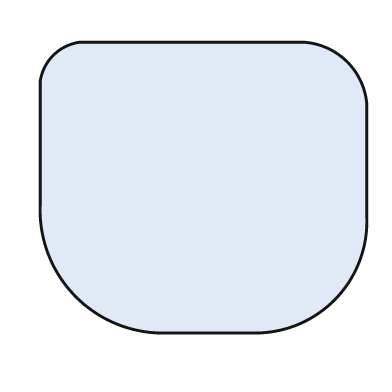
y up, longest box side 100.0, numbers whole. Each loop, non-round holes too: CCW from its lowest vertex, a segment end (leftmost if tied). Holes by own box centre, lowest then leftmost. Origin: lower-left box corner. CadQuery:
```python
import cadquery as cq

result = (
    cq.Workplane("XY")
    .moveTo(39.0, 0.0)
    .lineTo(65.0, 0.0)
    .threePointArc((90.0, 10.0), (100.0, 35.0))
    .lineTo(100.0, 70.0)
    .threePointArc((94.0, 83.0), (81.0, 89.0))
    .lineTo(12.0, 89.0)
    .threePointArc((4.0, 85.0), (0.0, 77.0))
    .lineTo(0.0, 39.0)
    .threePointArc((11.0, 11.0), (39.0, 0.0))
    .close()
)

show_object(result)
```